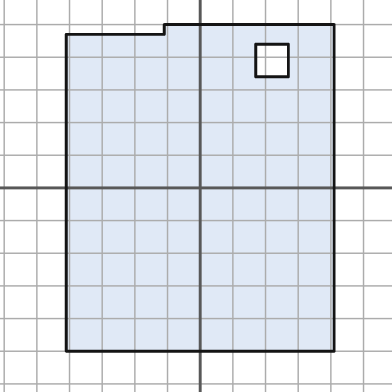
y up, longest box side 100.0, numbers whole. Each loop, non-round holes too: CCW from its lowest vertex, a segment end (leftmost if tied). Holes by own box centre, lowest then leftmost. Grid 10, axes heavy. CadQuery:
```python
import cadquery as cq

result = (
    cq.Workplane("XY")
    .moveTo(-41.0, -50.0)
    .lineTo(41.0, -50.0)
    .lineTo(41.0, 50.0)
    .lineTo(-11.0, 50.0)
    .lineTo(-11.0, 47.0)
    .lineTo(-41.0, 47.0)
    .close()
    .moveTo(17.0, 34.0)
    .lineTo(27.0, 34.0)
    .lineTo(27.0, 44.0)
    .lineTo(17.0, 44.0)
    .close()
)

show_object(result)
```